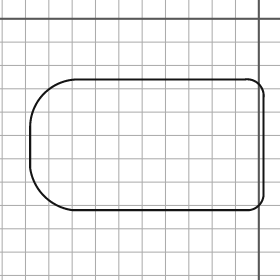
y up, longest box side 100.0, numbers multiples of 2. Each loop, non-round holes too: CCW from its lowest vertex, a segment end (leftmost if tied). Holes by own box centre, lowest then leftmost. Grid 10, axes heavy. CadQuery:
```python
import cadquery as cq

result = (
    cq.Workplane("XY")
    .moveTo(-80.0, -82.0)
    .lineTo(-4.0, -82.0)
    .threePointArc((0.0, -80.0), (2.0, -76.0))
    .lineTo(2.0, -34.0)
    .threePointArc((0.0, -28.0), (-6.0, -26.0))
    .lineTo(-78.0, -26.0)
    .threePointArc((-92.0, -32.0), (-98.0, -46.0))
    .lineTo(-98.0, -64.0)
    .threePointArc((-92.0, -76.0), (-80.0, -82.0))
    .close()
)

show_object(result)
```